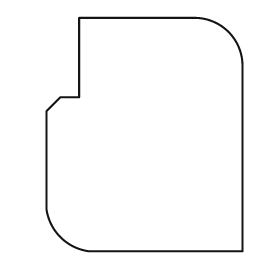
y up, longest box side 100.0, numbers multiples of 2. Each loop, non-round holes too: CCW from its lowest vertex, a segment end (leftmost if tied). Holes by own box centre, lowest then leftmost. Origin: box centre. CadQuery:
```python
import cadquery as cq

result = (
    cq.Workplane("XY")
    .moveTo(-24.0, -50.0)
    .lineTo(42.0, -50.0)
    .lineTo(42.0, 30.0)
    .threePointArc((36.0, 44.0), (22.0, 50.0))
    .lineTo(-28.0, 50.0)
    .lineTo(-28.0, 16.0)
    .lineTo(-36.0, 16.0)
    .lineTo(-42.0, 10.0)
    .lineTo(-42.0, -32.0)
    .threePointArc((-36.0, -44.0), (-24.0, -50.0))
    .close()
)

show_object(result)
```